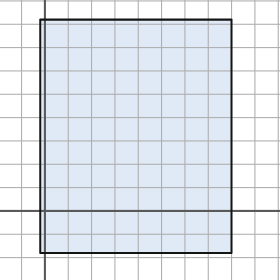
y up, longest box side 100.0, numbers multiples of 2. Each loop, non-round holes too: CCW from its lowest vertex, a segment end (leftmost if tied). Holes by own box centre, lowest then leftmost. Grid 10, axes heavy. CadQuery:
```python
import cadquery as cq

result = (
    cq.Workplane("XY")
    .moveTo(-2.0, -18.0)
    .lineTo(80.0, -18.0)
    .lineTo(80.0, 82.0)
    .lineTo(-2.0, 82.0)
    .close()
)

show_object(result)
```